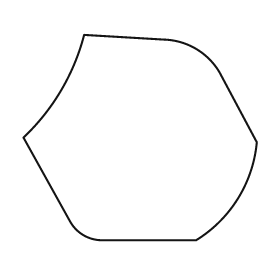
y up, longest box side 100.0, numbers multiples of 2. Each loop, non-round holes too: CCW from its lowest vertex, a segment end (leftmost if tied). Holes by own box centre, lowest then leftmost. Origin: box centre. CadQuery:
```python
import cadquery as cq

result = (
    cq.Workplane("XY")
    .moveTo(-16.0, -44.0)
    .lineTo(24.0, -44.0)
    .threePointArc((42.0, -26.0), (50.0, -2.0))
    .lineTo(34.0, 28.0)
    .threePointArc((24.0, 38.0), (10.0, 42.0))
    .lineTo(-24.0, 44.0)
    .threePointArc((-34.0, 20.0), (-50.0, 0.0))
    .lineTo(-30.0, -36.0)
    .threePointArc((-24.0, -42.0), (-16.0, -44.0))
    .close()
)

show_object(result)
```